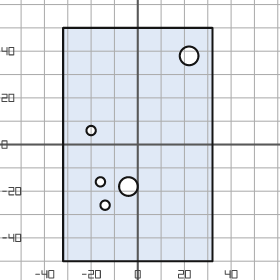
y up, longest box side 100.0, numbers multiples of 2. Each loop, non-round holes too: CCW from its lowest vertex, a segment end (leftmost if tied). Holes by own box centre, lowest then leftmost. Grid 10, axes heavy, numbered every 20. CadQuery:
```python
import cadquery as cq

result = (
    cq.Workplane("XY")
    .moveTo(-32.0, -50.0)
    .lineTo(32.0, -50.0)
    .lineTo(32.0, 50.0)
    .lineTo(-32.0, 50.0)
    .close()
    .moveTo(-14.0, -26.0)
    .circle(2.0)
    .moveTo(-4.0, -18.0)
    .circle(4.0)
    .moveTo(-16.0, -16.0)
    .circle(2.0)
    .moveTo(-20.0, 6.0)
    .circle(2.0)
    .moveTo(22.0, 38.0)
    .circle(4.0)
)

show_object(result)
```